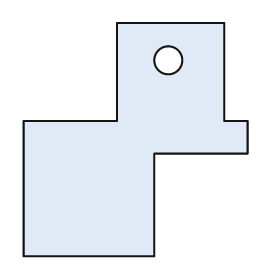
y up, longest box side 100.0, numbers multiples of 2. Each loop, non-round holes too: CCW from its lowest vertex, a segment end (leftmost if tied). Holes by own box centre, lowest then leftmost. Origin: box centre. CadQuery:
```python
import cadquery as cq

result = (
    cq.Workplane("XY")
    .moveTo(-48.0, -50.0)
    .lineTo(8.0, -50.0)
    .lineTo(8.0, -6.0)
    .lineTo(48.0, -6.0)
    .lineTo(48.0, 8.0)
    .lineTo(38.0, 8.0)
    .lineTo(38.0, 50.0)
    .lineTo(-8.0, 50.0)
    .lineTo(-8.0, 8.0)
    .lineTo(-48.0, 8.0)
    .close()
    .moveTo(14.0, 34.0)
    .circle(6.0)
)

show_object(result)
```